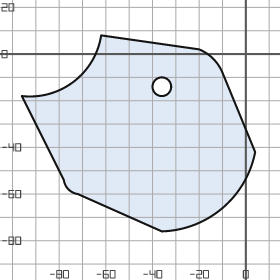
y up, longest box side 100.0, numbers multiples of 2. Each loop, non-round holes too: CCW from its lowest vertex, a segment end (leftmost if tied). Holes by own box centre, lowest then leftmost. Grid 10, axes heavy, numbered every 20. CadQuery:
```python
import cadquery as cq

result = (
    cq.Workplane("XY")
    .moveTo(-36.0, -76.0)
    .threePointArc((-10.0, -66.0), (4.0, -42.0))
    .lineTo(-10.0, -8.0)
    .threePointArc((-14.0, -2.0), (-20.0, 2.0))
    .lineTo(-62.0, 8.0)
    .threePointArc((-74.0, -12.0), (-96.0, -18.0))
    .lineTo(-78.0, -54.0)
    .threePointArc((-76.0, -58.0), (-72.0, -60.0))
    .close()
    .moveTo(-36.0, -14.0)
    .circle(4.0)
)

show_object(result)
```